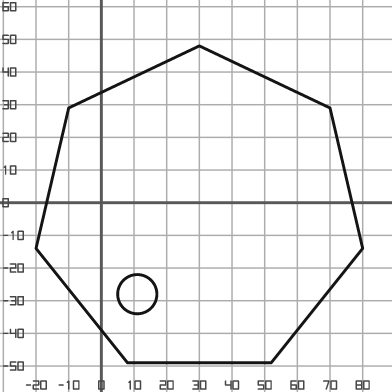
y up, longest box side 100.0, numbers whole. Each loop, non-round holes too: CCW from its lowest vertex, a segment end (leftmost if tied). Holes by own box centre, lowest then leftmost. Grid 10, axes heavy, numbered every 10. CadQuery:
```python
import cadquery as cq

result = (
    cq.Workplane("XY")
    .moveTo(8.0, -49.0)
    .lineTo(52.0, -49.0)
    .lineTo(80.0, -14.0)
    .lineTo(70.0, 29.0)
    .lineTo(30.0, 48.0)
    .lineTo(-10.0, 29.0)
    .lineTo(-20.0, -14.0)
    .close()
    .moveTo(11.0, -28.0)
    .circle(6.0)
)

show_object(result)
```